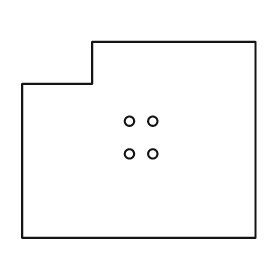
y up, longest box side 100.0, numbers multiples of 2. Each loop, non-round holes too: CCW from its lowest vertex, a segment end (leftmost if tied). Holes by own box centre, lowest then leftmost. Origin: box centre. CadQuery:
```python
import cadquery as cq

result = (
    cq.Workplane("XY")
    .moveTo(-50.0, -42.0)
    .lineTo(50.0, -42.0)
    .lineTo(50.0, 42.0)
    .lineTo(-20.0, 42.0)
    .lineTo(-20.0, 24.0)
    .lineTo(-50.0, 24.0)
    .close()
    .moveTo(-4.0, -6.0)
    .circle(2.0)
    .moveTo(6.0, -6.0)
    .circle(2.0)
    .moveTo(-4.0, 8.0)
    .circle(2.0)
    .moveTo(6.0, 8.0)
    .circle(2.0)
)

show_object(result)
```